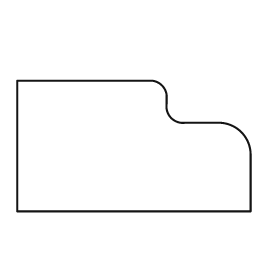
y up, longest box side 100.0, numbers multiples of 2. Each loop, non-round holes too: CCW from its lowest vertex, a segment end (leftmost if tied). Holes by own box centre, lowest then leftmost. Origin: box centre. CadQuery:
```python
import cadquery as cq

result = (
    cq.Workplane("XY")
    .moveTo(-50.0, -28.0)
    .lineTo(50.0, -28.0)
    .lineTo(50.0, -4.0)
    .threePointArc((46.0, 6.0), (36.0, 10.0))
    .lineTo(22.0, 10.0)
    .threePointArc((16.0, 12.0), (14.0, 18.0))
    .lineTo(14.0, 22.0)
    .threePointArc((12.0, 26.0), (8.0, 28.0))
    .lineTo(-50.0, 28.0)
    .close()
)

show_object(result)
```